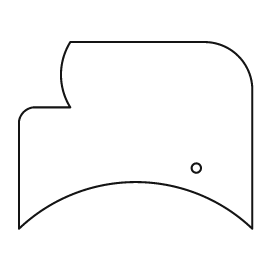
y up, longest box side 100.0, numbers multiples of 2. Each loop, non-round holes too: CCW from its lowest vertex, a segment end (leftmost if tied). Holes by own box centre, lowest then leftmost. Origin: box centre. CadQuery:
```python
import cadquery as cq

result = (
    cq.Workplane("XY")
    .moveTo(-50.0, -40.0)
    .threePointArc((0.0, -20.0), (50.0, -40.0))
    .lineTo(50.0, 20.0)
    .threePointArc((44.0, 34.0), (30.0, 40.0))
    .lineTo(-28.0, 40.0)
    .threePointArc((-32.0, 26.0), (-28.0, 12.0))
    .lineTo(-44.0, 12.0)
    .threePointArc((-48.0, 10.0), (-50.0, 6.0))
    .close()
    .moveTo(26.0, -14.0)
    .circle(2.0)
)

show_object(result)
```